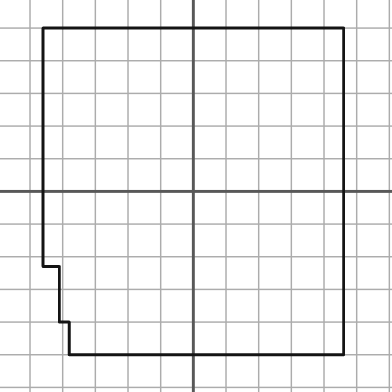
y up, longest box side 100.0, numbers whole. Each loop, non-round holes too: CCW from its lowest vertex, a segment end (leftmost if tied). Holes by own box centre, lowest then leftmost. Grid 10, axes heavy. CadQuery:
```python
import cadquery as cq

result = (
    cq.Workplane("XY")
    .moveTo(-38.0, -50.0)
    .lineTo(46.0, -50.0)
    .lineTo(46.0, 50.0)
    .lineTo(-46.0, 50.0)
    .lineTo(-46.0, -23.0)
    .lineTo(-41.0, -23.0)
    .lineTo(-41.0, -40.0)
    .lineTo(-38.0, -40.0)
    .close()
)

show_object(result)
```